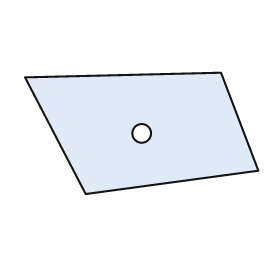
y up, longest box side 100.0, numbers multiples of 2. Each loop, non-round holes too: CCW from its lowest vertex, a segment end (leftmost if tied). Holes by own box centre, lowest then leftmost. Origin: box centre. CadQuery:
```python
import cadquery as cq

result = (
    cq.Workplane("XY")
    .moveTo(-24.0, -26.0)
    .lineTo(50.0, -16.0)
    .lineTo(34.0, 26.0)
    .lineTo(-50.0, 24.0)
    .close()
    .moveTo(0.0, 0.0)
    .circle(4.0)
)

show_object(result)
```